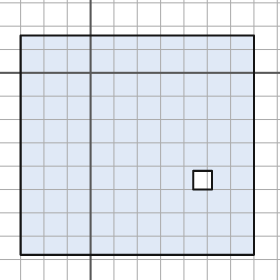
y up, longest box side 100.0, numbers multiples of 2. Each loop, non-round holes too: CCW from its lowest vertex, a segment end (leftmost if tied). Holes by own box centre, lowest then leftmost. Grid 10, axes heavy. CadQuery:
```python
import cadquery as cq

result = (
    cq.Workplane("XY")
    .moveTo(-30.0, -78.0)
    .lineTo(70.0, -78.0)
    .lineTo(70.0, 16.0)
    .lineTo(-30.0, 16.0)
    .close()
    .moveTo(44.0, -50.0)
    .lineTo(52.0, -50.0)
    .lineTo(52.0, -42.0)
    .lineTo(44.0, -42.0)
    .close()
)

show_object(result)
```